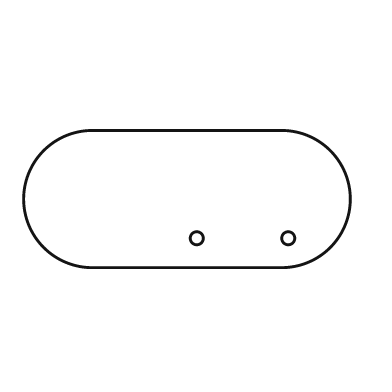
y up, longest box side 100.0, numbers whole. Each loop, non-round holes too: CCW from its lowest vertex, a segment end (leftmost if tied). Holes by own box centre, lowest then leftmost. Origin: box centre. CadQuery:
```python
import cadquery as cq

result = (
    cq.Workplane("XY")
    .moveTo(-29.0, -21.0)
    .lineTo(29.0, -21.0)
    .threePointArc((50.0, 0.0), (29.0, 21.0))
    .lineTo(-29.0, 21.0)
    .threePointArc((-50.0, 0.0), (-29.0, -21.0))
    .close()
    .moveTo(3.0, -12.0)
    .circle(2.0)
    .moveTo(31.0, -12.0)
    .circle(2.0)
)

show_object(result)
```